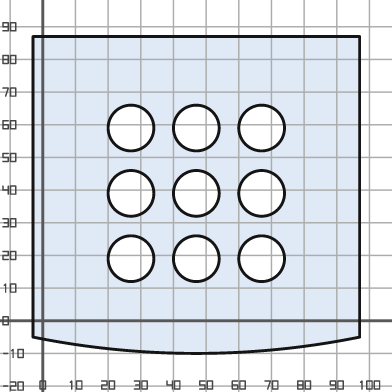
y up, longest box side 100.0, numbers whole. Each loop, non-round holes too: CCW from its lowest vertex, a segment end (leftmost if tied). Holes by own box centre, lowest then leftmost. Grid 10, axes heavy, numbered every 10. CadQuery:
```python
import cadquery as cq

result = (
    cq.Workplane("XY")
    .moveTo(-3.0, -5.0)
    .threePointArc((47.0, -10.0), (97.0, -5.0))
    .lineTo(97.0, 87.0)
    .lineTo(-3.0, 87.0)
    .close()
    .moveTo(27.0, 19.0)
    .circle(7.0)
    .moveTo(47.0, 19.0)
    .circle(7.0)
    .moveTo(67.0, 19.0)
    .circle(7.0)
    .moveTo(27.0, 39.0)
    .circle(7.0)
    .moveTo(47.0, 39.0)
    .circle(7.0)
    .moveTo(67.0, 39.0)
    .circle(7.0)
    .moveTo(27.0, 59.0)
    .circle(7.0)
    .moveTo(47.0, 59.0)
    .circle(7.0)
    .moveTo(67.0, 59.0)
    .circle(7.0)
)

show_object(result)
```